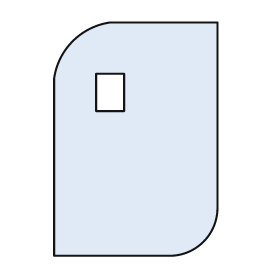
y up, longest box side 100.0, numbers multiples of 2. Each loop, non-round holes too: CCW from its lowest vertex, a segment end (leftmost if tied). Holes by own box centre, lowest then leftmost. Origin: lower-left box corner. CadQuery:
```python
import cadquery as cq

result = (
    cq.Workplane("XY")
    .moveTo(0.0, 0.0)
    .lineTo(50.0, 0.0)
    .threePointArc((64.0, 6.0), (70.0, 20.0))
    .lineTo(70.0, 100.0)
    .lineTo(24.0, 100.0)
    .threePointArc((8.0, 92.0), (0.0, 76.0))
    .close()
    .moveTo(18.0, 62.0)
    .lineTo(30.0, 62.0)
    .lineTo(30.0, 78.0)
    .lineTo(18.0, 78.0)
    .close()
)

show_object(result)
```